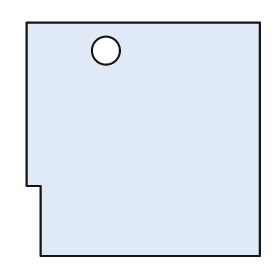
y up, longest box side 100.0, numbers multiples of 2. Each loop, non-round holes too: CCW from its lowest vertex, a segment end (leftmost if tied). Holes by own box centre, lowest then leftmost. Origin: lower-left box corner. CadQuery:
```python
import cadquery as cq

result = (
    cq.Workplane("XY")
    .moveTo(6.0, 0.0)
    .lineTo(100.0, 0.0)
    .lineTo(100.0, 100.0)
    .lineTo(0.0, 100.0)
    .lineTo(0.0, 30.0)
    .lineTo(6.0, 30.0)
    .close()
    .moveTo(34.0, 88.0)
    .circle(6.0)
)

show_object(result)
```